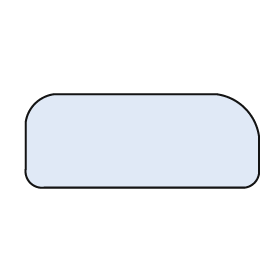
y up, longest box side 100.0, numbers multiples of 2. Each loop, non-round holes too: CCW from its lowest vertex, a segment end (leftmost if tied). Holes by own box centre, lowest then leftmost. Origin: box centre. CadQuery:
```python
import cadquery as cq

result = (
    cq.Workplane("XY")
    .moveTo(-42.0, -20.0)
    .lineTo(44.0, -20.0)
    .threePointArc((48.0, -18.0), (50.0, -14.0))
    .lineTo(50.0, 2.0)
    .threePointArc((44.0, 14.0), (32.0, 20.0))
    .lineTo(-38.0, 20.0)
    .threePointArc((-46.0, 16.0), (-50.0, 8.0))
    .lineTo(-50.0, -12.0)
    .threePointArc((-48.0, -18.0), (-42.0, -20.0))
    .close()
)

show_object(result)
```